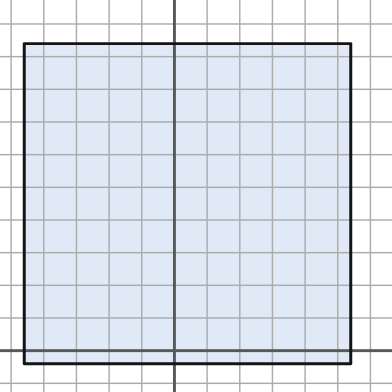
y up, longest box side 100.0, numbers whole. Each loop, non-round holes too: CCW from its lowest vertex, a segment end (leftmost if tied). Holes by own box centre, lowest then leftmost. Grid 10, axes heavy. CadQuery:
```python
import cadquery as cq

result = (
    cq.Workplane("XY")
    .moveTo(-46.0, -4.0)
    .lineTo(54.0, -4.0)
    .lineTo(54.0, 94.0)
    .lineTo(-46.0, 94.0)
    .close()
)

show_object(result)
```